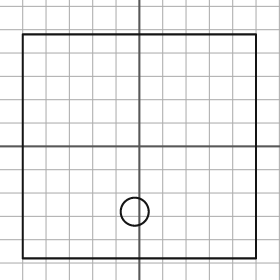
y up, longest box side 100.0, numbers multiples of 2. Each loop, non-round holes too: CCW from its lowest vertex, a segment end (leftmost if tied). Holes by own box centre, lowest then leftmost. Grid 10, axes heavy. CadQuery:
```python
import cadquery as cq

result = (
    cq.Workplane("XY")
    .moveTo(-50.0, -48.0)
    .lineTo(50.0, -48.0)
    .lineTo(50.0, 48.0)
    .lineTo(-50.0, 48.0)
    .close()
    .moveTo(-2.0, -28.0)
    .circle(6.0)
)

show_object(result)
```